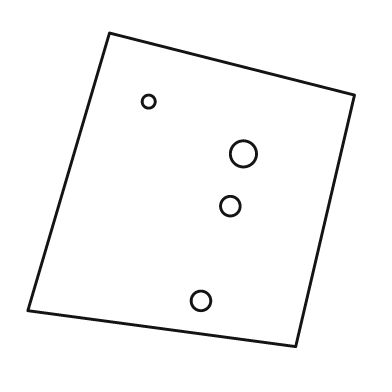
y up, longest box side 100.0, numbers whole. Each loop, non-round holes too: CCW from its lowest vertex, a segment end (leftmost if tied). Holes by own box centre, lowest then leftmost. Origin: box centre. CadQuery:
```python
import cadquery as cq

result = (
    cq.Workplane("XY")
    .moveTo(32.0, -48.0)
    .lineTo(50.0, 29.0)
    .lineTo(-25.0, 48.0)
    .lineTo(-50.0, -37.0)
    .close()
    .moveTo(3.0, -34.0)
    .circle(3.0)
    .moveTo(12.0, -5.0)
    .circle(3.0)
    .moveTo(16.0, 11.0)
    .circle(4.0)
    .moveTo(-13.0, 27.0)
    .circle(2.0)
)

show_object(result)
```